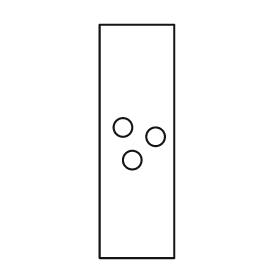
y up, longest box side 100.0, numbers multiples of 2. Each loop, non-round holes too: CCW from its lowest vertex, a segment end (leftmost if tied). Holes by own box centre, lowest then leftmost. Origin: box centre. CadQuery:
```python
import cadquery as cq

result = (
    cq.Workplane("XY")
    .moveTo(-16.0, -50.0)
    .lineTo(16.0, -50.0)
    .lineTo(16.0, 50.0)
    .lineTo(-16.0, 50.0)
    .close()
    .moveTo(-2.0, -8.0)
    .circle(4.0)
    .moveTo(8.0, 2.0)
    .circle(4.0)
    .moveTo(-6.0, 6.0)
    .circle(4.0)
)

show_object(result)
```